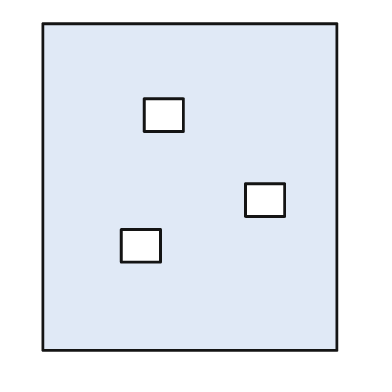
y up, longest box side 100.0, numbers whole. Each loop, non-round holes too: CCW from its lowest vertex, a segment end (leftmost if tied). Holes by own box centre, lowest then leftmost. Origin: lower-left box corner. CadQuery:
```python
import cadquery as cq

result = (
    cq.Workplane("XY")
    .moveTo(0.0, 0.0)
    .lineTo(90.0, 0.0)
    .lineTo(90.0, 100.0)
    .lineTo(0.0, 100.0)
    .close()
    .moveTo(24.0, 27.0)
    .lineTo(36.0, 27.0)
    .lineTo(36.0, 37.0)
    .lineTo(24.0, 37.0)
    .close()
    .moveTo(62.0, 41.0)
    .lineTo(74.0, 41.0)
    .lineTo(74.0, 51.0)
    .lineTo(62.0, 51.0)
    .close()
    .moveTo(31.0, 67.0)
    .lineTo(43.0, 67.0)
    .lineTo(43.0, 77.0)
    .lineTo(31.0, 77.0)
    .close()
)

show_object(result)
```